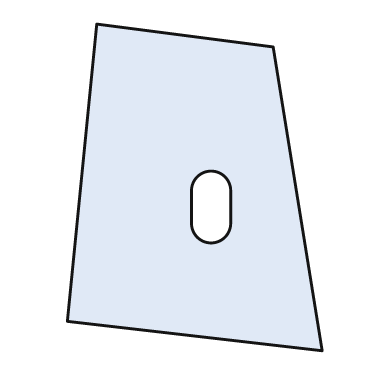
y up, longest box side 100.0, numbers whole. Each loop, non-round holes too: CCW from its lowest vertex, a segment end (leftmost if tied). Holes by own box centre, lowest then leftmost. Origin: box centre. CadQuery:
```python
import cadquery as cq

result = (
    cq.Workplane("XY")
    .moveTo(39.0, -50.0)
    .lineTo(24.0, 43.0)
    .lineTo(-30.0, 50.0)
    .lineTo(-39.0, -41.0)
    .close()
    .moveTo(-1.0, -11.0)
    .threePointArc((5.0, -17.0), (11.0, -11.0))
    .lineTo(11.0, -1.0)
    .threePointArc((5.0, 5.0), (-1.0, -1.0))
    .close()
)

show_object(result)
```